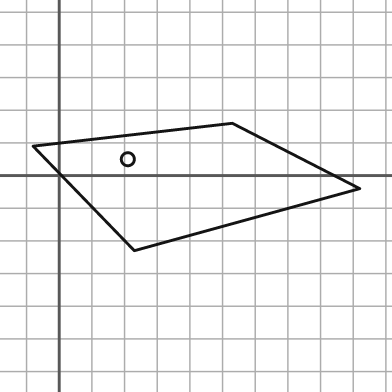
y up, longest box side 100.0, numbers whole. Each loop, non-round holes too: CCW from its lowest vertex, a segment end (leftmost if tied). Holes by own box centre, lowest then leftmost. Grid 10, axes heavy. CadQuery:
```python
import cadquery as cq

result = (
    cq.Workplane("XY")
    .moveTo(23.0, -23.0)
    .lineTo(92.0, -4.0)
    .lineTo(53.0, 16.0)
    .lineTo(-8.0, 9.0)
    .close()
    .moveTo(21.0, 5.0)
    .circle(2.0)
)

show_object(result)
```